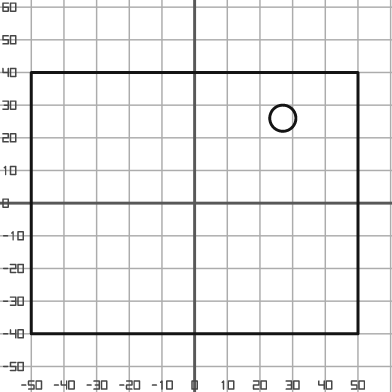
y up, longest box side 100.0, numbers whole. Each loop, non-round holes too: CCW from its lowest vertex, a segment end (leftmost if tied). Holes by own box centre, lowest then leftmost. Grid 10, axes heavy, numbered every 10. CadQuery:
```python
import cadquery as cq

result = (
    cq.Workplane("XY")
    .moveTo(-50.0, -40.0)
    .lineTo(50.0, -40.0)
    .lineTo(50.0, 40.0)
    .lineTo(-50.0, 40.0)
    .close()
    .moveTo(27.0, 26.0)
    .circle(4.0)
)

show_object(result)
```